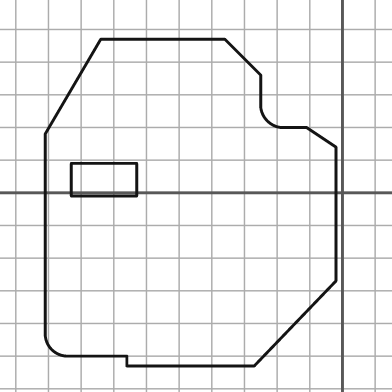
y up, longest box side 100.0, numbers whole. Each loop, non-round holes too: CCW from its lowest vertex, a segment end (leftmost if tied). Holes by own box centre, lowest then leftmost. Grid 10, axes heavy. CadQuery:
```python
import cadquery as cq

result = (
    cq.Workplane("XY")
    .moveTo(-66.0, -53.0)
    .lineTo(-27.0, -53.0)
    .lineTo(-2.0, -27.0)
    .lineTo(-2.0, 14.0)
    .lineTo(-11.0, 20.0)
    .lineTo(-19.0, 20.0)
    .threePointArc((-23.0, 22.0), (-25.0, 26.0))
    .lineTo(-25.0, 36.0)
    .lineTo(-36.0, 47.0)
    .lineTo(-74.0, 47.0)
    .lineTo(-91.0, 18.0)
    .lineTo(-91.0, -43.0)
    .threePointArc((-89.0, -48.0), (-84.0, -50.0))
    .lineTo(-66.0, -50.0)
    .close()
    .moveTo(-83.0, -1.0)
    .lineTo(-63.0, -1.0)
    .lineTo(-63.0, 9.0)
    .lineTo(-83.0, 9.0)
    .close()
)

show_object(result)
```